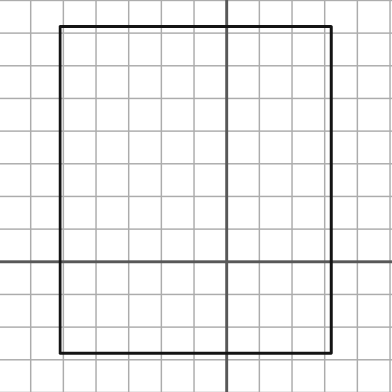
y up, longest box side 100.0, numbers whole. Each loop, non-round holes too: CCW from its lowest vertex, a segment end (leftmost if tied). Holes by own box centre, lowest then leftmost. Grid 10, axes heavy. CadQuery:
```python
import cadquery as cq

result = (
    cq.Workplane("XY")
    .moveTo(-51.0, -28.0)
    .lineTo(32.0, -28.0)
    .lineTo(32.0, 72.0)
    .lineTo(-51.0, 72.0)
    .close()
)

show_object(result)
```